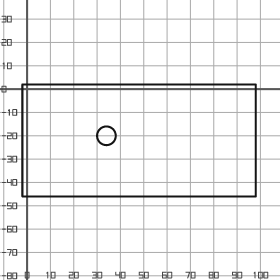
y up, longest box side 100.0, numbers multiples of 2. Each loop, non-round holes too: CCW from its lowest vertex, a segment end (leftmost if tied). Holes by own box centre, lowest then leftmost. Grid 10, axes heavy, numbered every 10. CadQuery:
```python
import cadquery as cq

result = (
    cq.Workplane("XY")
    .moveTo(-2.0, -46.0)
    .lineTo(98.0, -46.0)
    .lineTo(98.0, 2.0)
    .lineTo(-2.0, 2.0)
    .close()
    .moveTo(34.0, -20.0)
    .circle(4.0)
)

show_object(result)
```